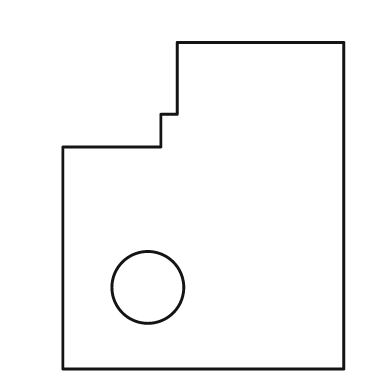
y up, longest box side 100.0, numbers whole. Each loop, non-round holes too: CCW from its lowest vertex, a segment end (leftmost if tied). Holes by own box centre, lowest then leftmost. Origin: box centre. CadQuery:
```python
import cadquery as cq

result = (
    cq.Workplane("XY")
    .moveTo(-43.0, -50.0)
    .lineTo(43.0, -50.0)
    .lineTo(43.0, 50.0)
    .lineTo(-8.0, 50.0)
    .lineTo(-8.0, 28.0)
    .lineTo(-13.0, 28.0)
    .lineTo(-13.0, 18.0)
    .lineTo(-43.0, 18.0)
    .close()
    .moveTo(-17.0, -25.0)
    .circle(11.0)
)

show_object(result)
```